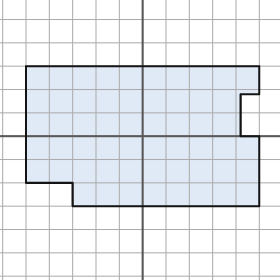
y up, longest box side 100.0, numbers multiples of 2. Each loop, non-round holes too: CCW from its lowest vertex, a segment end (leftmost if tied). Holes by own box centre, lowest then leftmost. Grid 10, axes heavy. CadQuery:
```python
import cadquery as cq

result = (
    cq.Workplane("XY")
    .moveTo(-30.0, -30.0)
    .lineTo(50.0, -30.0)
    .lineTo(50.0, 0.0)
    .lineTo(42.0, 0.0)
    .lineTo(42.0, 18.0)
    .lineTo(50.0, 18.0)
    .lineTo(50.0, 30.0)
    .lineTo(-50.0, 30.0)
    .lineTo(-50.0, -20.0)
    .lineTo(-30.0, -20.0)
    .close()
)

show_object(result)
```